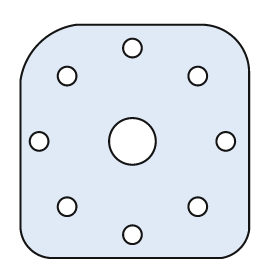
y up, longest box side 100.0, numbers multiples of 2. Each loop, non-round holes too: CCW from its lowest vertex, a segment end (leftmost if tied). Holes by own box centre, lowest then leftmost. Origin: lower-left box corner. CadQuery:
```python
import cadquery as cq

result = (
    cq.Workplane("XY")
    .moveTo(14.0, 0.0)
    .lineTo(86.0, 0.0)
    .threePointArc((94.0, 4.0), (98.0, 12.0))
    .lineTo(98.0, 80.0)
    .threePointArc((92.0, 94.0), (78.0, 100.0))
    .lineTo(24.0, 100.0)
    .threePointArc((8.0, 92.0), (0.0, 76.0))
    .lineTo(0.0, 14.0)
    .threePointArc((4.0, 4.0), (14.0, 0.0))
    .close()
    .moveTo(48.0, 10.0)
    .circle(4.0)
    .moveTo(20.0, 22.0)
    .circle(4.0)
    .moveTo(76.0, 22.0)
    .circle(4.0)
    .moveTo(8.0, 50.0)
    .circle(4.0)
    .moveTo(48.0, 50.0)
    .circle(10.0)
    .moveTo(88.0, 50.0)
    .circle(4.0)
    .moveTo(20.0, 78.0)
    .circle(4.0)
    .moveTo(76.0, 78.0)
    .circle(4.0)
    .moveTo(48.0, 90.0)
    .circle(4.0)
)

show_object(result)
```